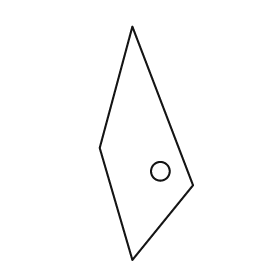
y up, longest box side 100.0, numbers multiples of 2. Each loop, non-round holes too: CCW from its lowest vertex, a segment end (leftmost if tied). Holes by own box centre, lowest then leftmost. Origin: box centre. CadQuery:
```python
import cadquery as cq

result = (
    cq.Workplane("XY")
    .moveTo(-6.0, -50.0)
    .lineTo(20.0, -18.0)
    .lineTo(-6.0, 50.0)
    .lineTo(-20.0, -2.0)
    .close()
    .moveTo(6.0, -12.0)
    .circle(4.0)
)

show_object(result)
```